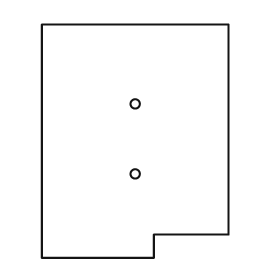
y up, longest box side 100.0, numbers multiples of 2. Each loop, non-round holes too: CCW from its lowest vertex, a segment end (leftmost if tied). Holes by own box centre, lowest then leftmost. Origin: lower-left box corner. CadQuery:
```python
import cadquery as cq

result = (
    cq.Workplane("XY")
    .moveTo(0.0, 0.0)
    .lineTo(48.0, 0.0)
    .lineTo(48.0, 10.0)
    .lineTo(80.0, 10.0)
    .lineTo(80.0, 100.0)
    .lineTo(0.0, 100.0)
    .close()
    .moveTo(40.0, 36.0)
    .circle(2.0)
    .moveTo(40.0, 66.0)
    .circle(2.0)
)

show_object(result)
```